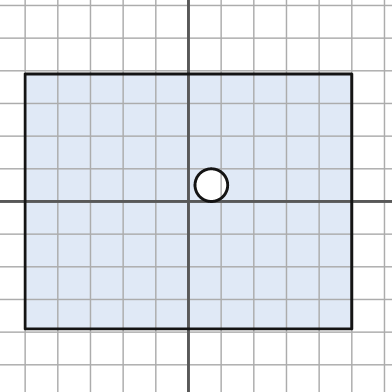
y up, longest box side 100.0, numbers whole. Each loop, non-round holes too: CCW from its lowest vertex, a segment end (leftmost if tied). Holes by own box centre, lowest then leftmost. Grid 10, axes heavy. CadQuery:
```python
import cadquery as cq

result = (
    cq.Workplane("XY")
    .moveTo(-50.0, -39.0)
    .lineTo(50.0, -39.0)
    .lineTo(50.0, 39.0)
    .lineTo(-50.0, 39.0)
    .close()
    .moveTo(7.0, 5.0)
    .circle(5.0)
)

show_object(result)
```